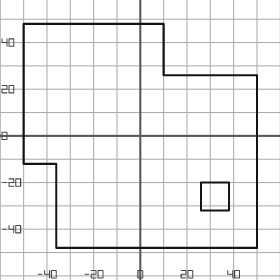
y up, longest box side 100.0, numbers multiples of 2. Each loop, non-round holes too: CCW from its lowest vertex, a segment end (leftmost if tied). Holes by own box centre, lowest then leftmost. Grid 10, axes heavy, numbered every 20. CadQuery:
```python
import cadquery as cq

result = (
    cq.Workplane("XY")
    .moveTo(-36.0, -48.0)
    .lineTo(50.0, -48.0)
    .lineTo(50.0, 26.0)
    .lineTo(10.0, 26.0)
    .lineTo(10.0, 48.0)
    .lineTo(-50.0, 48.0)
    .lineTo(-50.0, -12.0)
    .lineTo(-36.0, -12.0)
    .close()
    .moveTo(26.0, -32.0)
    .lineTo(38.0, -32.0)
    .lineTo(38.0, -20.0)
    .lineTo(26.0, -20.0)
    .close()
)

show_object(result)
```